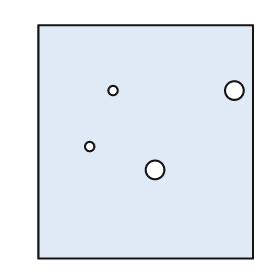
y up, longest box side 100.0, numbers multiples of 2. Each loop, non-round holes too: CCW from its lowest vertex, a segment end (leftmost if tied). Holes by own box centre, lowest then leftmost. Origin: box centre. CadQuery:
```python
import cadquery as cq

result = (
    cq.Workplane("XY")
    .moveTo(-46.0, -50.0)
    .lineTo(46.0, -50.0)
    .lineTo(46.0, 50.0)
    .lineTo(-46.0, 50.0)
    .close()
    .moveTo(4.0, -12.0)
    .circle(4.0)
    .moveTo(-24.0, -2.0)
    .circle(2.0)
    .moveTo(-14.0, 22.0)
    .circle(2.0)
    .moveTo(38.0, 22.0)
    .circle(4.0)
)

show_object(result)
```